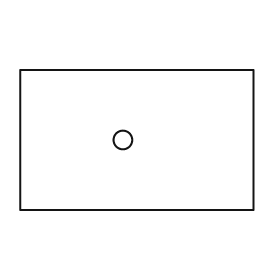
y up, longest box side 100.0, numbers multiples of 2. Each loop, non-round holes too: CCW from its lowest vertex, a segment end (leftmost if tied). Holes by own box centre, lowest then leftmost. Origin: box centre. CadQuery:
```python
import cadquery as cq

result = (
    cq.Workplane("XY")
    .moveTo(-50.0, -30.0)
    .lineTo(50.0, -30.0)
    .lineTo(50.0, 30.0)
    .lineTo(-50.0, 30.0)
    .close()
    .moveTo(-6.0, 0.0)
    .circle(4.0)
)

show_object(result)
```